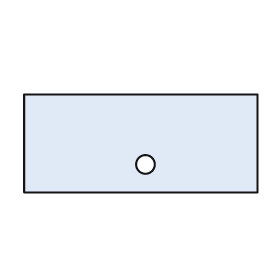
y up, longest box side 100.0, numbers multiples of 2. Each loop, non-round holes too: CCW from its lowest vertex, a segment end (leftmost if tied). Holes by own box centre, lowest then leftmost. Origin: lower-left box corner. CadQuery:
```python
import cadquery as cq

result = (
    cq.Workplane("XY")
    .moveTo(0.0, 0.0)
    .lineTo(100.0, 0.0)
    .lineTo(100.0, 42.0)
    .lineTo(0.0, 42.0)
    .close()
    .moveTo(52.0, 12.0)
    .circle(4.0)
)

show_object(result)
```